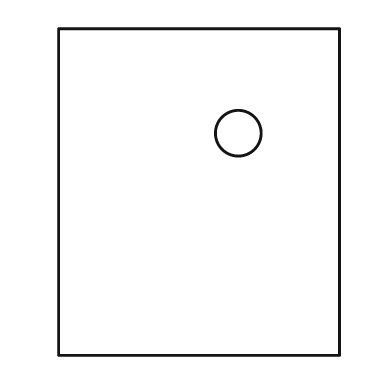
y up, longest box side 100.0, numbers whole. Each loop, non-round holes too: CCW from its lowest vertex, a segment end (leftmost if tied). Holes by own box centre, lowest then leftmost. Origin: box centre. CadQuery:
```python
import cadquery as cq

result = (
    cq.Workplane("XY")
    .moveTo(-43.0, -50.0)
    .lineTo(43.0, -50.0)
    .lineTo(43.0, 50.0)
    .lineTo(-43.0, 50.0)
    .close()
    .moveTo(12.0, 18.0)
    .circle(7.0)
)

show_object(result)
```